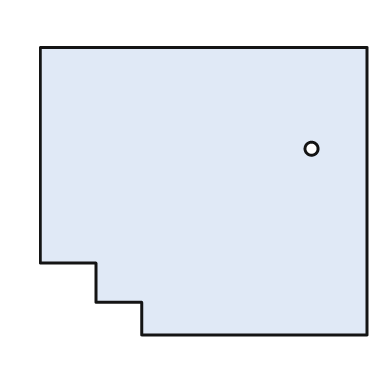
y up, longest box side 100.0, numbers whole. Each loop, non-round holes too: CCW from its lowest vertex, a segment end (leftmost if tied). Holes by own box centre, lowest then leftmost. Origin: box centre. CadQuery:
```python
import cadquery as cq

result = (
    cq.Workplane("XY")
    .moveTo(-19.0, -44.0)
    .lineTo(50.0, -44.0)
    .lineTo(50.0, 44.0)
    .lineTo(-50.0, 44.0)
    .lineTo(-50.0, -22.0)
    .lineTo(-33.0, -22.0)
    .lineTo(-33.0, -34.0)
    .lineTo(-19.0, -34.0)
    .close()
    .moveTo(33.0, 13.0)
    .circle(2.0)
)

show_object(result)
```